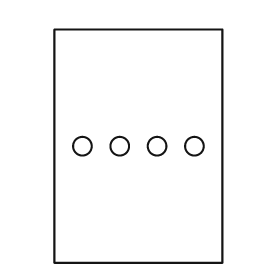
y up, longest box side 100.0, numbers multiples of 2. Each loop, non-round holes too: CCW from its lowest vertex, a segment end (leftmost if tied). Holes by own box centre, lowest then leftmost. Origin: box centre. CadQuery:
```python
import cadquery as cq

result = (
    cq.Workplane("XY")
    .moveTo(-36.0, -50.0)
    .lineTo(36.0, -50.0)
    .lineTo(36.0, 50.0)
    .lineTo(-36.0, 50.0)
    .close()
    .moveTo(-24.0, 0.0)
    .circle(4.0)
    .moveTo(-8.0, 0.0)
    .circle(4.0)
    .moveTo(8.0, 0.0)
    .circle(4.0)
    .moveTo(24.0, 0.0)
    .circle(4.0)
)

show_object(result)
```